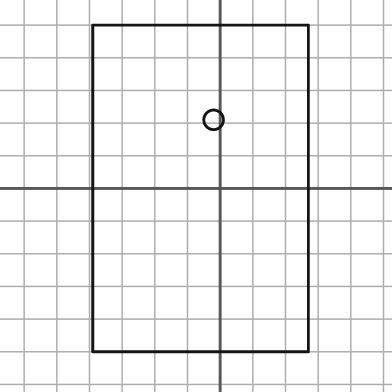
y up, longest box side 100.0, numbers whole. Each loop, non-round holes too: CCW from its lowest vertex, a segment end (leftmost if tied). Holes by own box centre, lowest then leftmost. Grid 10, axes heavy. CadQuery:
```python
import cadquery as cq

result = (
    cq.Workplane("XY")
    .moveTo(-39.0, -50.0)
    .lineTo(27.0, -50.0)
    .lineTo(27.0, 50.0)
    .lineTo(-39.0, 50.0)
    .close()
    .moveTo(-2.0, 21.0)
    .circle(3.0)
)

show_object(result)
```